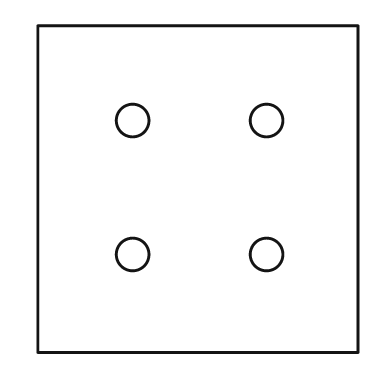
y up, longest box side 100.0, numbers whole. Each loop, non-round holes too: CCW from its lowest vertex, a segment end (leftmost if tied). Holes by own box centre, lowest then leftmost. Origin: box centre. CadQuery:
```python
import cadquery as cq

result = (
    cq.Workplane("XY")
    .moveTo(-49.0, -50.0)
    .lineTo(49.0, -50.0)
    .lineTo(49.0, 50.0)
    .lineTo(-49.0, 50.0)
    .close()
    .moveTo(-20.0, -20.0)
    .circle(5.0)
    .moveTo(21.0, -20.0)
    .circle(5.0)
    .moveTo(-20.0, 21.0)
    .circle(5.0)
    .moveTo(21.0, 21.0)
    .circle(5.0)
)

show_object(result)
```